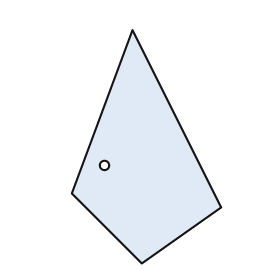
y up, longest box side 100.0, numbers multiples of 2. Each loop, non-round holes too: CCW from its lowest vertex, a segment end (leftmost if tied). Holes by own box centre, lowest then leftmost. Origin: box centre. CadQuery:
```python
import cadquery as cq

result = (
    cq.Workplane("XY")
    .moveTo(-2.0, -50.0)
    .lineTo(32.0, -26.0)
    .lineTo(-6.0, 50.0)
    .lineTo(-32.0, -20.0)
    .close()
    .moveTo(-18.0, -8.0)
    .circle(2.0)
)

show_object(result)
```